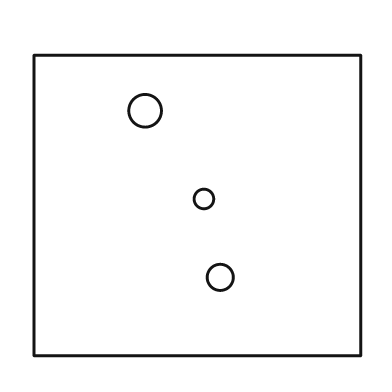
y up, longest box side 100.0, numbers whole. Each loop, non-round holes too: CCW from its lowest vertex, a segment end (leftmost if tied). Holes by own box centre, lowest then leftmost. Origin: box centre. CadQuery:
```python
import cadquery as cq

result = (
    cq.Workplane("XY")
    .moveTo(-50.0, -46.0)
    .lineTo(50.0, -46.0)
    .lineTo(50.0, 46.0)
    .lineTo(-50.0, 46.0)
    .close()
    .moveTo(7.0, -22.0)
    .circle(4.0)
    .moveTo(2.0, 2.0)
    .circle(3.0)
    .moveTo(-16.0, 29.0)
    .circle(5.0)
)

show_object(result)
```